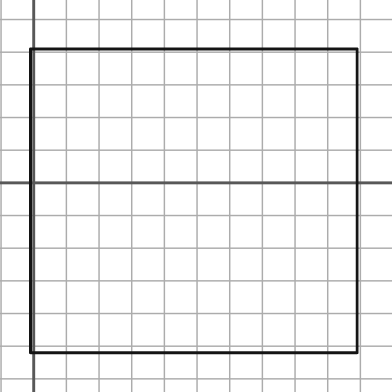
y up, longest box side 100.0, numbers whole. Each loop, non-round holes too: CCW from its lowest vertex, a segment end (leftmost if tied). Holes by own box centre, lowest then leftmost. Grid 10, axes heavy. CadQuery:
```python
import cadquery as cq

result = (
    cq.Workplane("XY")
    .moveTo(-1.0, -52.0)
    .lineTo(99.0, -52.0)
    .lineTo(99.0, 41.0)
    .lineTo(-1.0, 41.0)
    .close()
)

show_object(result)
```